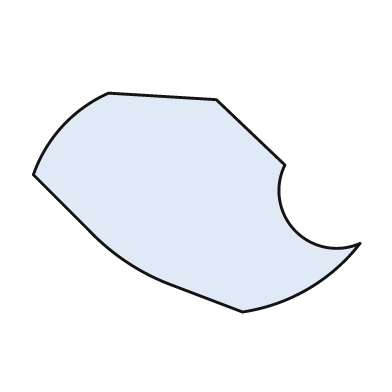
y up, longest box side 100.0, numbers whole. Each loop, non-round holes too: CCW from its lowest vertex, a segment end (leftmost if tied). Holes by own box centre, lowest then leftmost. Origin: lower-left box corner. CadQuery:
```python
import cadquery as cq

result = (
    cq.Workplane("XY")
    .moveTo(64.0, 0.0)
    .threePointArc((84.0, 7.0), (100.0, 21.0))
    .threePointArc((80.0, 25.0), (77.0, 45.0))
    .lineTo(56.0, 65.0)
    .lineTo(23.0, 67.0)
    .threePointArc((9.0, 57.0), (0.0, 42.0))
    .lineTo(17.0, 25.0)
    .threePointArc((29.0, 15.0), (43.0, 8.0))
    .close()
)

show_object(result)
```